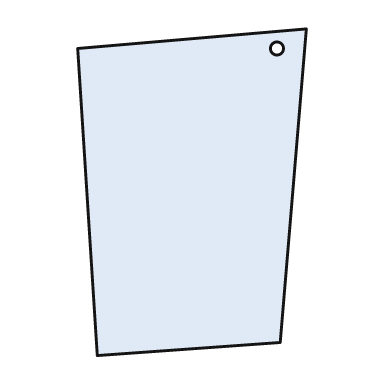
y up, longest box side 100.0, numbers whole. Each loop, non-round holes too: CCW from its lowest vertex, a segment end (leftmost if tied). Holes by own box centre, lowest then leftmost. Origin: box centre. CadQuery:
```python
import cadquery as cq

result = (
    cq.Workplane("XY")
    .moveTo(-29.0, -50.0)
    .lineTo(27.0, -46.0)
    .lineTo(35.0, 50.0)
    .lineTo(-35.0, 44.0)
    .close()
    .moveTo(26.0, 44.0)
    .circle(2.0)
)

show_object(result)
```